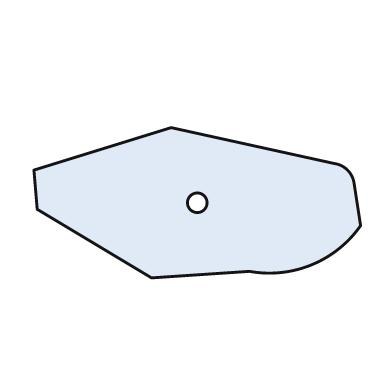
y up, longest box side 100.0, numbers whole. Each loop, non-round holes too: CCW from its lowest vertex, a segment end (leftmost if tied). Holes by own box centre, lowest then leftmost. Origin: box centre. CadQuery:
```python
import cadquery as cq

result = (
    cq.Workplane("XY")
    .moveTo(-14.0, -23.0)
    .lineTo(16.0, -21.0)
    .threePointArc((35.0, -19.0), (50.0, -7.0))
    .lineTo(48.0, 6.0)
    .threePointArc((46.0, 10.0), (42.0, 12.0))
    .lineTo(-8.0, 23.0)
    .lineTo(-50.0, 10.0)
    .lineTo(-49.0, -2.0)
    .close()
    .moveTo(0.0, 0.0)
    .circle(3.0)
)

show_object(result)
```